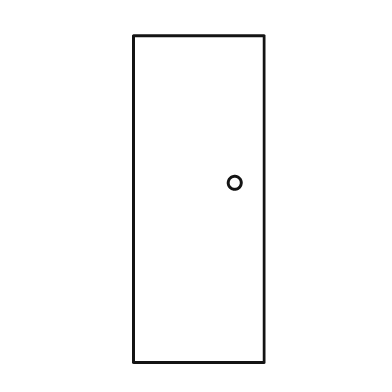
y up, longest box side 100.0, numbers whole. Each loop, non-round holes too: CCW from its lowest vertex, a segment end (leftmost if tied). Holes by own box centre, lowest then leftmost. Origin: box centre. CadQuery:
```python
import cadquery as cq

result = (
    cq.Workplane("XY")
    .moveTo(-20.0, -50.0)
    .lineTo(20.0, -50.0)
    .lineTo(20.0, 50.0)
    .lineTo(-20.0, 50.0)
    .close()
    .moveTo(11.0, 5.0)
    .circle(2.0)
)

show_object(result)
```